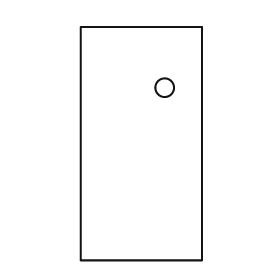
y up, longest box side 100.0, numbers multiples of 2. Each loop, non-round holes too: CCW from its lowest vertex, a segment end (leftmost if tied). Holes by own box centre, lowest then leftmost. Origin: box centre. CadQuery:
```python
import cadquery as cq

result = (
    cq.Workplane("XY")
    .moveTo(-26.0, -50.0)
    .lineTo(26.0, -50.0)
    .lineTo(26.0, 50.0)
    .lineTo(-26.0, 50.0)
    .close()
    .moveTo(10.0, 24.0)
    .circle(4.0)
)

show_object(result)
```